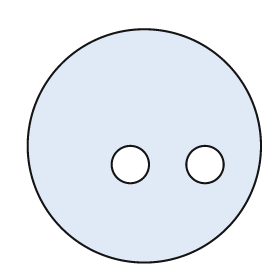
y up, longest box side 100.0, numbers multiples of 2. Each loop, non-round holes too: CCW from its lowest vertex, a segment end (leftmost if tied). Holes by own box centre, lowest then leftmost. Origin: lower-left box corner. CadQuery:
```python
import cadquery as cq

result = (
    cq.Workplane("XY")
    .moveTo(50.0, 50.0)
    .circle(50.0)
    .moveTo(44.0, 42.0)
    .circle(8.0)
    .moveTo(76.0, 42.0)
    .circle(8.0)
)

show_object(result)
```